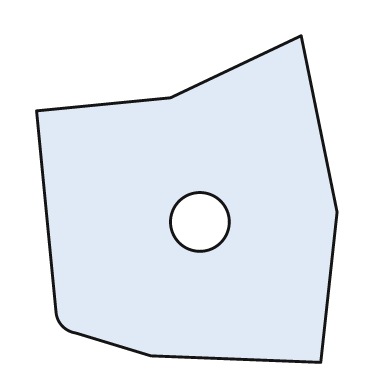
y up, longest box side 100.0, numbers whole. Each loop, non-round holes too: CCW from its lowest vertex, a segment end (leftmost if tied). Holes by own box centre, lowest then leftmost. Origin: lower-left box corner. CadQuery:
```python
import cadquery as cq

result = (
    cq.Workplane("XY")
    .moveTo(87.0, 0.0)
    .lineTo(92.0, 46.0)
    .lineTo(81.0, 100.0)
    .lineTo(41.0, 81.0)
    .lineTo(0.0, 77.0)
    .lineTo(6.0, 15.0)
    .threePointArc((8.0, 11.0), (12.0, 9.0))
    .lineTo(35.0, 2.0)
    .close()
    .moveTo(50.0, 43.0)
    .circle(9.0)
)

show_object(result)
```